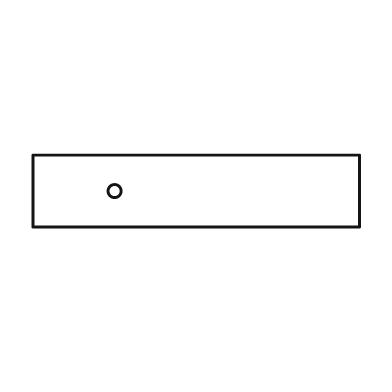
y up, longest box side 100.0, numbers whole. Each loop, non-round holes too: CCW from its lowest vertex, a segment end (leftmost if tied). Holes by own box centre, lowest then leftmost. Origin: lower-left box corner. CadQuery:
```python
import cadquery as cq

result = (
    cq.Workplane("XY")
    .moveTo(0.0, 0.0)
    .lineTo(100.0, 0.0)
    .lineTo(100.0, 22.0)
    .lineTo(0.0, 22.0)
    .close()
    .moveTo(25.0, 11.0)
    .circle(2.0)
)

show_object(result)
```